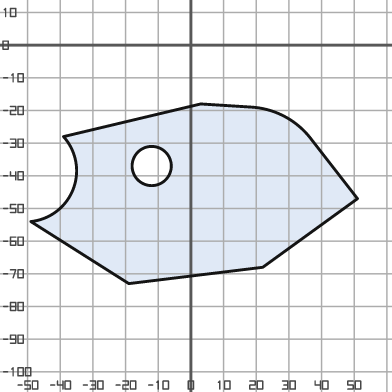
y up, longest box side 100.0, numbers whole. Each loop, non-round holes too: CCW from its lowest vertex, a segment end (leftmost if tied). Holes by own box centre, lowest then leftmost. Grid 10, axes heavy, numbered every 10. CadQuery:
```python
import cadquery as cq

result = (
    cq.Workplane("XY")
    .moveTo(-19.0, -73.0)
    .lineTo(22.0, -68.0)
    .lineTo(51.0, -47.0)
    .lineTo(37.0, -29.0)
    .threePointArc((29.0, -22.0), (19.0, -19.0))
    .lineTo(3.0, -18.0)
    .lineTo(-39.0, -28.0)
    .threePointArc((-36.0, -44.0), (-49.0, -54.0))
    .close()
    .moveTo(-12.0, -37.0)
    .circle(6.0)
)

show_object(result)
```